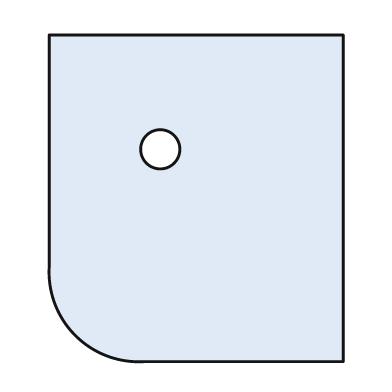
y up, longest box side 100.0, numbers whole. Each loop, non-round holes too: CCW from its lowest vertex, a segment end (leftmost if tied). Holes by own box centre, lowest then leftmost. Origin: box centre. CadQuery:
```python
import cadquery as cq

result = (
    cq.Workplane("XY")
    .moveTo(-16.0, -50.0)
    .lineTo(45.0, -50.0)
    .lineTo(45.0, 50.0)
    .lineTo(-45.0, 50.0)
    .lineTo(-45.0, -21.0)
    .threePointArc((-37.0, -42.0), (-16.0, -50.0))
    .close()
    .moveTo(-11.0, 15.0)
    .circle(6.0)
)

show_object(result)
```